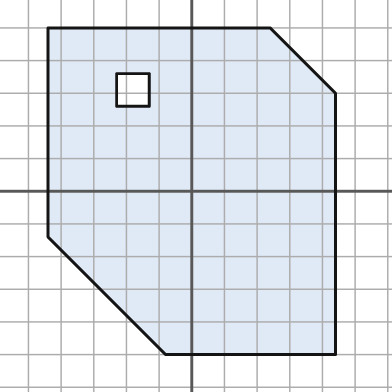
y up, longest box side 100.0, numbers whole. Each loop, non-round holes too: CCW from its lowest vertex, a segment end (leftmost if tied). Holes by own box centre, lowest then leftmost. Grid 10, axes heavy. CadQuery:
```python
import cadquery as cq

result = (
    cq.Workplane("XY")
    .moveTo(-8.0, -50.0)
    .lineTo(44.0, -50.0)
    .lineTo(44.0, 30.0)
    .lineTo(24.0, 50.0)
    .lineTo(-44.0, 50.0)
    .lineTo(-44.0, -14.0)
    .close()
    .moveTo(-23.0, 26.0)
    .lineTo(-13.0, 26.0)
    .lineTo(-13.0, 36.0)
    .lineTo(-23.0, 36.0)
    .close()
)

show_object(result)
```